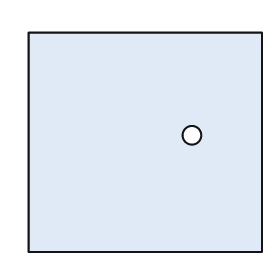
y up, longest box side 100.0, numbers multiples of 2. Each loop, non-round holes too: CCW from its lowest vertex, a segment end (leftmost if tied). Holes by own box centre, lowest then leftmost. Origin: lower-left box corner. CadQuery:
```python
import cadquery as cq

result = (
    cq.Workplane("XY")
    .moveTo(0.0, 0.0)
    .lineTo(100.0, 0.0)
    .lineTo(100.0, 94.0)
    .lineTo(0.0, 94.0)
    .close()
    .moveTo(70.0, 50.0)
    .circle(4.0)
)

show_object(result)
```